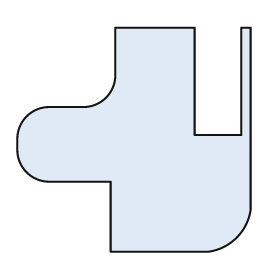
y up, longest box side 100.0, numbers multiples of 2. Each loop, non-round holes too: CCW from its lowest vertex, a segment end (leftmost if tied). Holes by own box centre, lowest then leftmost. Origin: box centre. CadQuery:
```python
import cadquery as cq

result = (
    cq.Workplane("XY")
    .moveTo(-10.0, -48.0)
    .lineTo(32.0, -48.0)
    .threePointArc((44.0, -42.0), (50.0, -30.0))
    .lineTo(50.0, 48.0)
    .lineTo(46.0, 48.0)
    .lineTo(46.0, 2.0)
    .lineTo(26.0, 2.0)
    .lineTo(26.0, 48.0)
    .lineTo(-8.0, 48.0)
    .lineTo(-8.0, 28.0)
    .threePointArc((-12.0, 18.0), (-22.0, 14.0))
    .lineTo(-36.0, 14.0)
    .threePointArc((-46.0, 10.0), (-50.0, 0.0))
    .lineTo(-50.0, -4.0)
    .threePointArc((-46.0, -14.0), (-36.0, -18.0))
    .lineTo(-10.0, -18.0)
    .close()
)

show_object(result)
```